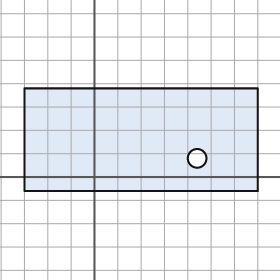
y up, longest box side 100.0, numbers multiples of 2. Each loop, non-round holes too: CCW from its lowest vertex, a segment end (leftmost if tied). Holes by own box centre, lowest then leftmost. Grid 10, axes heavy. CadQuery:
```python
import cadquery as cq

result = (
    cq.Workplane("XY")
    .moveTo(-30.0, -6.0)
    .lineTo(70.0, -6.0)
    .lineTo(70.0, 38.0)
    .lineTo(-30.0, 38.0)
    .close()
    .moveTo(44.0, 8.0)
    .circle(4.0)
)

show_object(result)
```